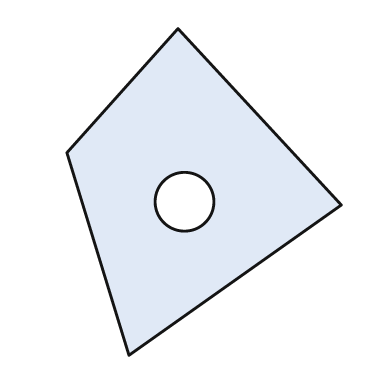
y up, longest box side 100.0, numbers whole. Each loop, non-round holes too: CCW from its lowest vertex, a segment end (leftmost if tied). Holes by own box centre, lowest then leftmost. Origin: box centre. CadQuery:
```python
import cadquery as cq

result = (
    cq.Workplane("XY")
    .moveTo(-23.0, -50.0)
    .lineTo(42.0, -4.0)
    .lineTo(-8.0, 50.0)
    .lineTo(-42.0, 12.0)
    .close()
    .moveTo(-6.0, -3.0)
    .circle(9.0)
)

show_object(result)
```